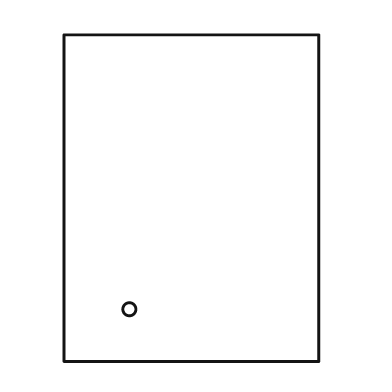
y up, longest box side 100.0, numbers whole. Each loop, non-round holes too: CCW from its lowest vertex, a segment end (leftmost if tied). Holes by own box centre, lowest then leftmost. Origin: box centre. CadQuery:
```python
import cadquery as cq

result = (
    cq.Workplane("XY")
    .moveTo(-39.0, -50.0)
    .lineTo(39.0, -50.0)
    .lineTo(39.0, 50.0)
    .lineTo(-39.0, 50.0)
    .close()
    .moveTo(-19.0, -34.0)
    .circle(2.0)
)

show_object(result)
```